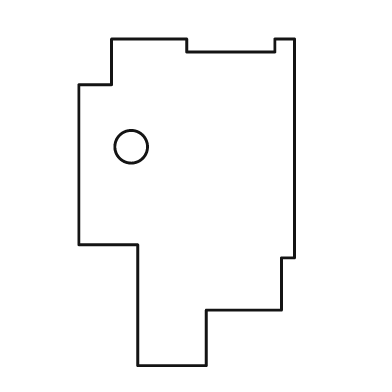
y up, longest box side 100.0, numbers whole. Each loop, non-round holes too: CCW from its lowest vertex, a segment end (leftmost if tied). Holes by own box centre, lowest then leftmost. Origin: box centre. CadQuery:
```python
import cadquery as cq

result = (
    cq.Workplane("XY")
    .moveTo(-15.0, -50.0)
    .lineTo(6.0, -50.0)
    .lineTo(6.0, -33.0)
    .lineTo(29.0, -33.0)
    .lineTo(29.0, -17.0)
    .lineTo(33.0, -17.0)
    .lineTo(33.0, 50.0)
    .lineTo(27.0, 50.0)
    .lineTo(27.0, 46.0)
    .lineTo(0.0, 46.0)
    .lineTo(0.0, 50.0)
    .lineTo(-23.0, 50.0)
    .lineTo(-23.0, 36.0)
    .lineTo(-33.0, 36.0)
    .lineTo(-33.0, -13.0)
    .lineTo(-15.0, -13.0)
    .close()
    .moveTo(-17.0, 17.0)
    .circle(5.0)
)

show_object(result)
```